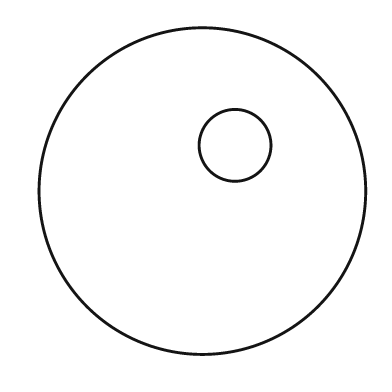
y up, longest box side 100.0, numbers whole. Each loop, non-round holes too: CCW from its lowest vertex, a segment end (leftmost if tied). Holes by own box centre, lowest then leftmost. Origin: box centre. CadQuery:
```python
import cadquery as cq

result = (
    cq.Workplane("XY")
    .moveTo(0.0, 0.0)
    .circle(50.0)
    .moveTo(10.0, 14.0)
    .circle(11.0)
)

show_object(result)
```